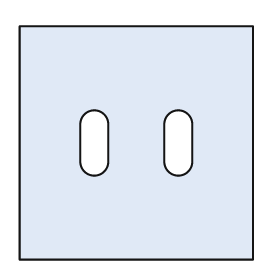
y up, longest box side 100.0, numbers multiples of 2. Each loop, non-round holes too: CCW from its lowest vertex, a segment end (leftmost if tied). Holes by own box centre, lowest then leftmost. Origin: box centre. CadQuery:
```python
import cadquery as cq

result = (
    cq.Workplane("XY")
    .moveTo(-50.0, -50.0)
    .lineTo(50.0, -50.0)
    .lineTo(50.0, 50.0)
    .lineTo(-50.0, 50.0)
    .close()
    .moveTo(-24.0, -8.0)
    .threePointArc((-18.0, -14.0), (-12.0, -8.0))
    .lineTo(-12.0, 8.0)
    .threePointArc((-18.0, 14.0), (-24.0, 8.0))
    .close()
    .moveTo(12.0, -8.0)
    .threePointArc((18.0, -14.0), (24.0, -8.0))
    .lineTo(24.0, 8.0)
    .threePointArc((18.0, 14.0), (12.0, 8.0))
    .close()
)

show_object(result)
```